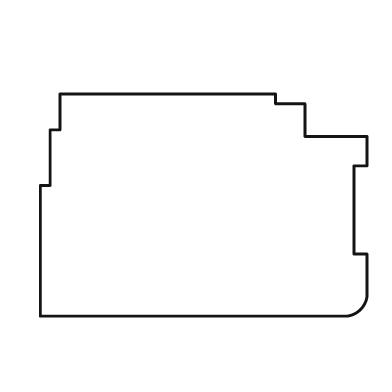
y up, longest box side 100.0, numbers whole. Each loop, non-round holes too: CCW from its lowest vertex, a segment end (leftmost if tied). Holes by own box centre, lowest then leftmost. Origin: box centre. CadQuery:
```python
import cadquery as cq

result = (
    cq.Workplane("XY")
    .moveTo(-50.0, -34.0)
    .lineTo(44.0, -34.0)
    .threePointArc((48.0, -32.0), (50.0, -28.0))
    .lineTo(50.0, -15.0)
    .lineTo(46.0, -15.0)
    .lineTo(46.0, 12.0)
    .lineTo(50.0, 12.0)
    .lineTo(50.0, 21.0)
    .lineTo(31.0, 21.0)
    .lineTo(31.0, 31.0)
    .lineTo(22.0, 31.0)
    .lineTo(22.0, 34.0)
    .lineTo(-44.0, 34.0)
    .lineTo(-44.0, 23.0)
    .lineTo(-47.0, 23.0)
    .lineTo(-47.0, 6.0)
    .lineTo(-50.0, 6.0)
    .close()
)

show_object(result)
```